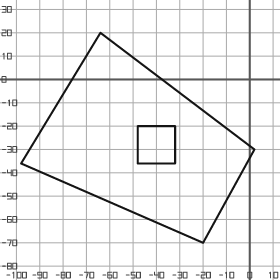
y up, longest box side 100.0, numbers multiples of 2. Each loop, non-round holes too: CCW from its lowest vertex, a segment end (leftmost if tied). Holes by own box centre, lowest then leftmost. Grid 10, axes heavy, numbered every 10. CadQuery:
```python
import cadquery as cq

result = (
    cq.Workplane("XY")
    .moveTo(-20.0, -70.0)
    .lineTo(2.0, -30.0)
    .lineTo(-64.0, 20.0)
    .lineTo(-98.0, -36.0)
    .close()
    .moveTo(-48.0, -36.0)
    .lineTo(-32.0, -36.0)
    .lineTo(-32.0, -20.0)
    .lineTo(-48.0, -20.0)
    .close()
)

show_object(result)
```